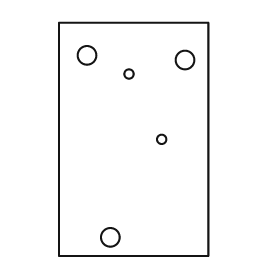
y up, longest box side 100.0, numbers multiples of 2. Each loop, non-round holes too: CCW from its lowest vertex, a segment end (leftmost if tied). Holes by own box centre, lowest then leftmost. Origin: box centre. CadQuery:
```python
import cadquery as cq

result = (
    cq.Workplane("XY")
    .moveTo(-32.0, -50.0)
    .lineTo(32.0, -50.0)
    .lineTo(32.0, 50.0)
    .lineTo(-32.0, 50.0)
    .close()
    .moveTo(-10.0, -42.0)
    .circle(4.0)
    .moveTo(12.0, 0.0)
    .circle(2.0)
    .moveTo(-2.0, 28.0)
    .circle(2.0)
    .moveTo(22.0, 34.0)
    .circle(4.0)
    .moveTo(-20.0, 36.0)
    .circle(4.0)
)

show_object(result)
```